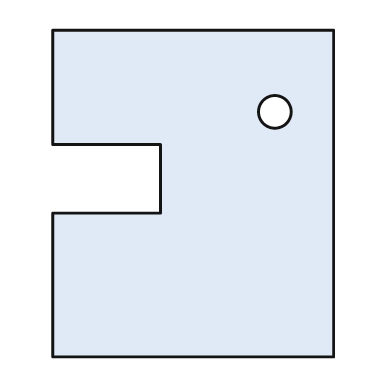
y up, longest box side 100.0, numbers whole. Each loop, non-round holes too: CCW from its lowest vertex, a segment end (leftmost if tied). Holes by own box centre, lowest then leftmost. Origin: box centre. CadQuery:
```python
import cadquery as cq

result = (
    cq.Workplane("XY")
    .moveTo(-43.0, -50.0)
    .lineTo(43.0, -50.0)
    .lineTo(43.0, 50.0)
    .lineTo(-43.0, 50.0)
    .lineTo(-43.0, 15.0)
    .lineTo(-10.0, 15.0)
    .lineTo(-10.0, -6.0)
    .lineTo(-43.0, -6.0)
    .close()
    .moveTo(25.0, 25.0)
    .circle(5.0)
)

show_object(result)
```